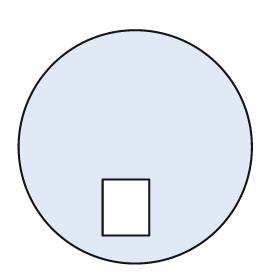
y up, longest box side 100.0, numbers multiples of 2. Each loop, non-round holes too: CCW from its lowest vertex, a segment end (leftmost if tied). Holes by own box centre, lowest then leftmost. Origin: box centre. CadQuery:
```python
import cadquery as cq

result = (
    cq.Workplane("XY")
    .moveTo(0.0, 0.0)
    .circle(50.0)
    .moveTo(-14.0, -38.0)
    .lineTo(6.0, -38.0)
    .lineTo(6.0, -14.0)
    .lineTo(-14.0, -14.0)
    .close()
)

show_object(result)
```